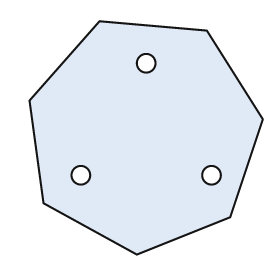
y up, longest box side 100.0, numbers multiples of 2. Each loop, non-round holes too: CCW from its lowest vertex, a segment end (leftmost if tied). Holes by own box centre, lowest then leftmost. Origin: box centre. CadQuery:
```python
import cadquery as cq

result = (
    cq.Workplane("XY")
    .moveTo(-4.0, -50.0)
    .lineTo(36.0, -34.0)
    .lineTo(50.0, 8.0)
    .lineTo(26.0, 46.0)
    .lineTo(-20.0, 50.0)
    .lineTo(-50.0, 16.0)
    .lineTo(-44.0, -28.0)
    .close()
    .moveTo(-28.0, -16.0)
    .circle(4.0)
    .moveTo(28.0, -16.0)
    .circle(4.0)
    .moveTo(0.0, 32.0)
    .circle(4.0)
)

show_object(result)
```